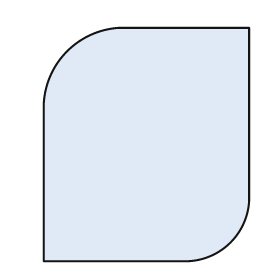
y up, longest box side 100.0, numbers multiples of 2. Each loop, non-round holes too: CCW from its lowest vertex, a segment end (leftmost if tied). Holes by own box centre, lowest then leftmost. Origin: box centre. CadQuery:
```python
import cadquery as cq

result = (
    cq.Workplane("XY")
    .moveTo(-44.0, -50.0)
    .lineTo(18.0, -50.0)
    .threePointArc((36.0, -42.0), (44.0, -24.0))
    .lineTo(44.0, 50.0)
    .lineTo(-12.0, 50.0)
    .threePointArc((-34.0, 40.0), (-44.0, 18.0))
    .close()
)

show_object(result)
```